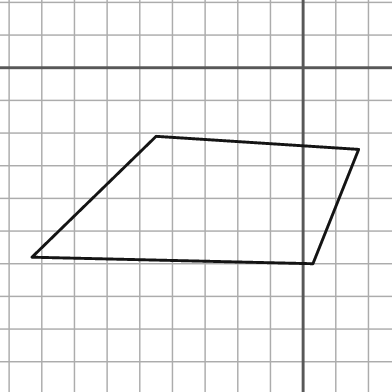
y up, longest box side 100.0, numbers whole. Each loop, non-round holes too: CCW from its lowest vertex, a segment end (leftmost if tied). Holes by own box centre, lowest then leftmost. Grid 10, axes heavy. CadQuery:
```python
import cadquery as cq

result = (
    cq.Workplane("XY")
    .moveTo(3.0, -60.0)
    .lineTo(17.0, -25.0)
    .lineTo(-45.0, -21.0)
    .lineTo(-83.0, -58.0)
    .close()
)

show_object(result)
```